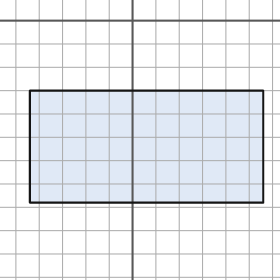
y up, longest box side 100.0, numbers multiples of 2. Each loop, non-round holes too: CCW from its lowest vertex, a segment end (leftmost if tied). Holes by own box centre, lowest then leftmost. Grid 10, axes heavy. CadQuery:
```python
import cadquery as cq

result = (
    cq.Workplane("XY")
    .moveTo(-44.0, -78.0)
    .lineTo(56.0, -78.0)
    .lineTo(56.0, -30.0)
    .lineTo(-44.0, -30.0)
    .close()
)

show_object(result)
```